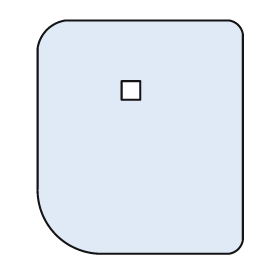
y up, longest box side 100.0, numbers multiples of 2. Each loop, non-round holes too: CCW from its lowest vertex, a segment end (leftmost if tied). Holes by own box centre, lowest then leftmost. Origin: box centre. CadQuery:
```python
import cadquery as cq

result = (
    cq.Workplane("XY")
    .moveTo(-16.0, -50.0)
    .lineTo(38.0, -50.0)
    .threePointArc((42.0, -48.0), (44.0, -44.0))
    .lineTo(44.0, 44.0)
    .threePointArc((42.0, 48.0), (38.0, 50.0))
    .lineTo(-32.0, 50.0)
    .threePointArc((-40.0, 46.0), (-44.0, 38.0))
    .lineTo(-44.0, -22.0)
    .threePointArc((-36.0, -42.0), (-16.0, -50.0))
    .close()
    .moveTo(-8.0, 16.0)
    .lineTo(0.0, 16.0)
    .lineTo(0.0, 24.0)
    .lineTo(-8.0, 24.0)
    .close()
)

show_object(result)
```